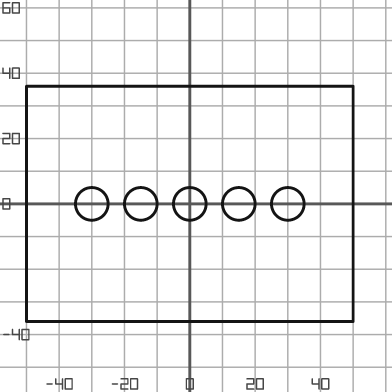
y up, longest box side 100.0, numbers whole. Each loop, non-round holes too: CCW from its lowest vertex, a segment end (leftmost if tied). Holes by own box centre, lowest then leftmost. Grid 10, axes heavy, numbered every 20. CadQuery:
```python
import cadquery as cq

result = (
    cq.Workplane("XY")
    .moveTo(-50.0, -36.0)
    .lineTo(50.0, -36.0)
    .lineTo(50.0, 36.0)
    .lineTo(-50.0, 36.0)
    .close()
    .moveTo(-30.0, 0.0)
    .circle(5.0)
    .moveTo(-15.0, 0.0)
    .circle(5.0)
    .moveTo(0.0, 0.0)
    .circle(5.0)
    .moveTo(15.0, 0.0)
    .circle(5.0)
    .moveTo(30.0, 0.0)
    .circle(5.0)
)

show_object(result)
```